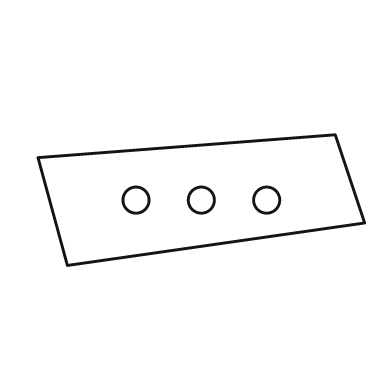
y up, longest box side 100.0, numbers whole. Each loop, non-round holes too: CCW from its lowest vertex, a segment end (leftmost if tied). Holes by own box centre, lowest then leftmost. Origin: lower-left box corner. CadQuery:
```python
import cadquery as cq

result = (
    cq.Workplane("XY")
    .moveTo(9.0, 0.0)
    .lineTo(100.0, 13.0)
    .lineTo(91.0, 40.0)
    .lineTo(0.0, 33.0)
    .close()
    .moveTo(30.0, 20.0)
    .circle(4.0)
    .moveTo(50.0, 20.0)
    .circle(4.0)
    .moveTo(70.0, 20.0)
    .circle(4.0)
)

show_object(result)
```